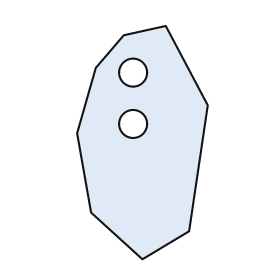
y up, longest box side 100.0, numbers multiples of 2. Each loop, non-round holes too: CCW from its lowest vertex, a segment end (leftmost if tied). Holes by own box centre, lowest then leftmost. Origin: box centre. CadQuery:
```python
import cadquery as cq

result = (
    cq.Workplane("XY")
    .moveTo(0.0, -50.0)
    .lineTo(20.0, -38.0)
    .lineTo(28.0, 16.0)
    .lineTo(10.0, 50.0)
    .lineTo(-8.0, 46.0)
    .lineTo(-20.0, 32.0)
    .lineTo(-28.0, 4.0)
    .lineTo(-22.0, -30.0)
    .close()
    .moveTo(-4.0, 8.0)
    .circle(6.0)
    .moveTo(-4.0, 30.0)
    .circle(6.0)
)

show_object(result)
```